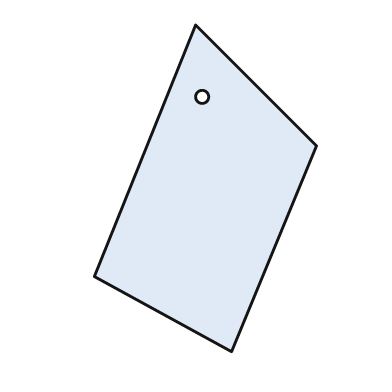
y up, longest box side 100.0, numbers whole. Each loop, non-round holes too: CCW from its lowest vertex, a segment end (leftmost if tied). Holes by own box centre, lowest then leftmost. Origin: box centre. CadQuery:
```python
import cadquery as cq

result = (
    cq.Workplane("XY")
    .moveTo(8.0, -50.0)
    .lineTo(34.0, 13.0)
    .lineTo(-3.0, 50.0)
    .lineTo(-34.0, -27.0)
    .close()
    .moveTo(-1.0, 28.0)
    .circle(2.0)
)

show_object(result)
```